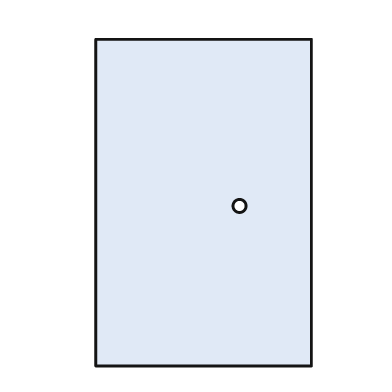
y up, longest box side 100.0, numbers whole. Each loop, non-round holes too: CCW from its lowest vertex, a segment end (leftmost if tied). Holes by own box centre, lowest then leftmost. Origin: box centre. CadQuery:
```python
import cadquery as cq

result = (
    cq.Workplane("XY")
    .moveTo(-33.0, -50.0)
    .lineTo(33.0, -50.0)
    .lineTo(33.0, 50.0)
    .lineTo(-33.0, 50.0)
    .close()
    .moveTo(11.0, -1.0)
    .circle(2.0)
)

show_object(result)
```